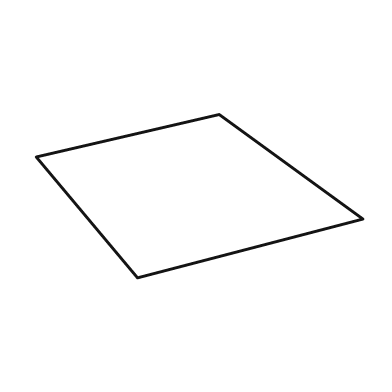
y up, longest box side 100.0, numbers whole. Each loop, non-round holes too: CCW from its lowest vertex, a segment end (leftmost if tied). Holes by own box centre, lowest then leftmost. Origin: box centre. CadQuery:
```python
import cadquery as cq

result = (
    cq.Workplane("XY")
    .moveTo(-19.0, -25.0)
    .lineTo(50.0, -7.0)
    .lineTo(6.0, 25.0)
    .lineTo(-50.0, 12.0)
    .close()
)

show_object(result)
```